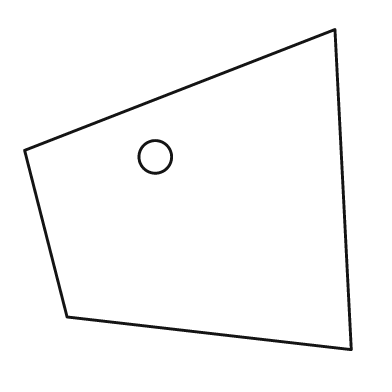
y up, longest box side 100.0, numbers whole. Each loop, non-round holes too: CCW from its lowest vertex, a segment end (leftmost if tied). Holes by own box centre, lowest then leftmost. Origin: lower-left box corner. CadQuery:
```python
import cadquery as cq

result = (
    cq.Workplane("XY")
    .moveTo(100.0, 0.0)
    .lineTo(95.0, 98.0)
    .lineTo(0.0, 61.0)
    .lineTo(13.0, 10.0)
    .close()
    .moveTo(40.0, 59.0)
    .circle(5.0)
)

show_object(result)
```